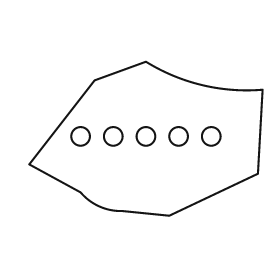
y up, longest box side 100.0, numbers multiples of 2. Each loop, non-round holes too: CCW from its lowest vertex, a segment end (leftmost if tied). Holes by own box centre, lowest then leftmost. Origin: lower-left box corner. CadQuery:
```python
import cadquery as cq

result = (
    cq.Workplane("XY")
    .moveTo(60.0, 0.0)
    .lineTo(98.0, 18.0)
    .lineTo(100.0, 54.0)
    .threePointArc((74.0, 56.0), (50.0, 66.0))
    .lineTo(28.0, 58.0)
    .lineTo(0.0, 22.0)
    .lineTo(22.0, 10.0)
    .threePointArc((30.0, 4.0), (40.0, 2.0))
    .close()
    .moveTo(22.0, 34.0)
    .circle(4.0)
    .moveTo(36.0, 34.0)
    .circle(4.0)
    .moveTo(50.0, 34.0)
    .circle(4.0)
    .moveTo(64.0, 34.0)
    .circle(4.0)
    .moveTo(78.0, 34.0)
    .circle(4.0)
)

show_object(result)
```